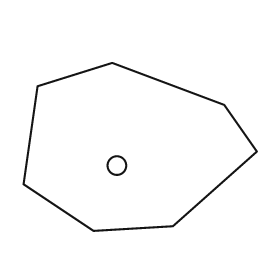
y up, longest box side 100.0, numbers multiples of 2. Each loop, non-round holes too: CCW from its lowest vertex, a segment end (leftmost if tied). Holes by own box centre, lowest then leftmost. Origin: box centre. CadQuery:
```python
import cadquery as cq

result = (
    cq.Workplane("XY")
    .moveTo(-20.0, -36.0)
    .lineTo(14.0, -34.0)
    .lineTo(50.0, -2.0)
    .lineTo(36.0, 18.0)
    .lineTo(-12.0, 36.0)
    .lineTo(-44.0, 26.0)
    .lineTo(-50.0, -16.0)
    .close()
    .moveTo(-10.0, -8.0)
    .circle(4.0)
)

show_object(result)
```